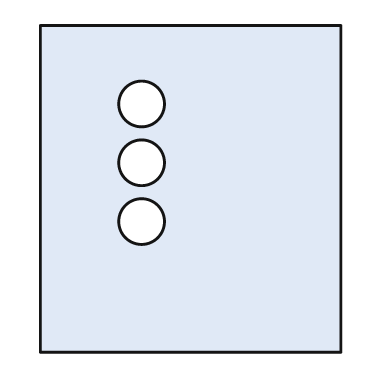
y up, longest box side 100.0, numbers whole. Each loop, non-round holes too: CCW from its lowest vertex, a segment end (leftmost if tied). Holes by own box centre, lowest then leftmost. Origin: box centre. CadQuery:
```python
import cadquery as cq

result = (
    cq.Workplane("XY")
    .moveTo(-46.0, -50.0)
    .lineTo(46.0, -50.0)
    .lineTo(46.0, 50.0)
    .lineTo(-46.0, 50.0)
    .close()
    .moveTo(-15.0, -10.0)
    .circle(7.0)
    .moveTo(-15.0, 8.0)
    .circle(7.0)
    .moveTo(-15.0, 26.0)
    .circle(7.0)
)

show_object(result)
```